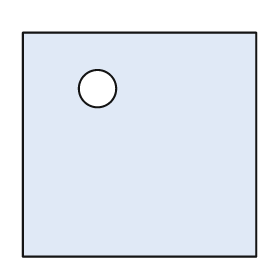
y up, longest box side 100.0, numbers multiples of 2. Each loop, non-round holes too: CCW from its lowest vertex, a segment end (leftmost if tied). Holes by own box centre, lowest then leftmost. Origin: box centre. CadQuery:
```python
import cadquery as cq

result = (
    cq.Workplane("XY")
    .moveTo(-50.0, -48.0)
    .lineTo(50.0, -48.0)
    .lineTo(50.0, 48.0)
    .lineTo(-50.0, 48.0)
    .close()
    .moveTo(-18.0, 24.0)
    .circle(8.0)
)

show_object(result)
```